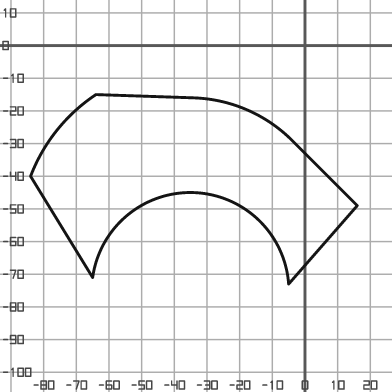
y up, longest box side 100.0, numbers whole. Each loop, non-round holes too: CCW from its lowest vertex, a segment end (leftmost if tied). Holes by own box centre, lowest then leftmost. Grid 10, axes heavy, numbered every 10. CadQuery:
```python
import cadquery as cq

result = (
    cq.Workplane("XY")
    .moveTo(-5.0, -73.0)
    .lineTo(16.0, -49.0)
    .lineTo(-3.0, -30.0)
    .threePointArc((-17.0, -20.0), (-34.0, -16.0))
    .lineTo(-64.0, -15.0)
    .threePointArc((-76.0, -26.0), (-84.0, -40.0))
    .lineTo(-65.0, -71.0)
    .threePointArc((-34.0, -45.0), (-5.0, -73.0))
    .close()
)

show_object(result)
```